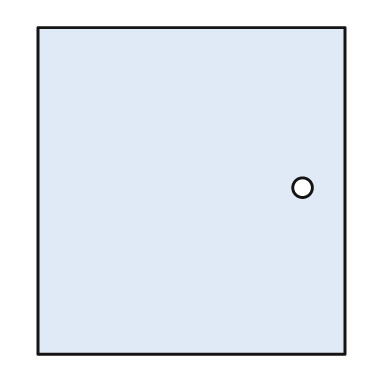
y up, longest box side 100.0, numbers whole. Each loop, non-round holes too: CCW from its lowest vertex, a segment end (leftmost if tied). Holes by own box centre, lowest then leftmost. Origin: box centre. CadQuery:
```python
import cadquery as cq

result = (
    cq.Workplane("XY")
    .moveTo(-47.0, -50.0)
    .lineTo(47.0, -50.0)
    .lineTo(47.0, 50.0)
    .lineTo(-47.0, 50.0)
    .close()
    .moveTo(34.0, 1.0)
    .circle(3.0)
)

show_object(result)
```